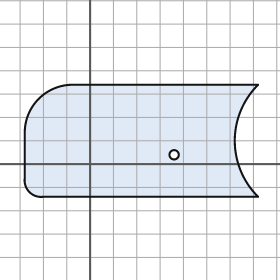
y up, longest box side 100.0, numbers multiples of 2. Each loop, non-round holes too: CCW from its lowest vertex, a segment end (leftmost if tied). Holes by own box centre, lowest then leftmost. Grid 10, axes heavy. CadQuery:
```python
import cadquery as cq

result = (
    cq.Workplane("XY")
    .moveTo(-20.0, -14.0)
    .lineTo(72.0, -14.0)
    .threePointArc((62.0, 10.0), (72.0, 34.0))
    .lineTo(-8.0, 34.0)
    .threePointArc((-22.0, 28.0), (-28.0, 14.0))
    .lineTo(-28.0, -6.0)
    .threePointArc((-26.0, -12.0), (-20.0, -14.0))
    .close()
    .moveTo(36.0, 4.0)
    .circle(2.0)
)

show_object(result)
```